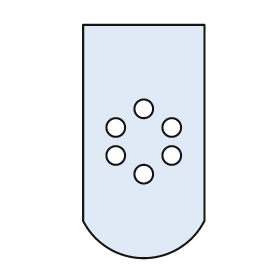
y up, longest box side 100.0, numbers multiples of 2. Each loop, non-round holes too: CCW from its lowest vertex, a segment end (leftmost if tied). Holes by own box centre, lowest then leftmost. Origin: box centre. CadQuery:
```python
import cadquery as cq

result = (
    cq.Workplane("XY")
    .moveTo(-26.0, -34.0)
    .threePointArc((0.0, -50.0), (26.0, -34.0))
    .lineTo(26.0, 50.0)
    .lineTo(-26.0, 50.0)
    .close()
    .moveTo(0.0, -14.0)
    .circle(4.0)
    .moveTo(-12.0, -6.0)
    .circle(4.0)
    .moveTo(12.0, -6.0)
    .circle(4.0)
    .moveTo(-12.0, 6.0)
    .circle(4.0)
    .moveTo(12.0, 6.0)
    .circle(4.0)
    .moveTo(0.0, 14.0)
    .circle(4.0)
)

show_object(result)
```